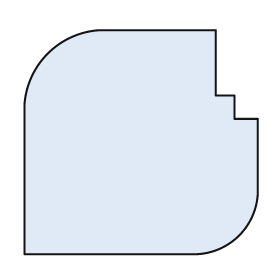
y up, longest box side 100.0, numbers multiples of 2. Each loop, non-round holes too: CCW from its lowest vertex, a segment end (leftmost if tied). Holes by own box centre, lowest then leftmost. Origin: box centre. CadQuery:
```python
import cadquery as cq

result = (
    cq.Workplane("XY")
    .moveTo(-50.0, -48.0)
    .lineTo(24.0, -48.0)
    .threePointArc((42.0, -40.0), (50.0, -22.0))
    .lineTo(50.0, 10.0)
    .lineTo(40.0, 10.0)
    .lineTo(40.0, 20.0)
    .lineTo(32.0, 20.0)
    .lineTo(32.0, 48.0)
    .lineTo(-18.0, 48.0)
    .threePointArc((-40.0, 38.0), (-50.0, 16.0))
    .close()
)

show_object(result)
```